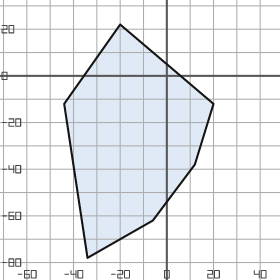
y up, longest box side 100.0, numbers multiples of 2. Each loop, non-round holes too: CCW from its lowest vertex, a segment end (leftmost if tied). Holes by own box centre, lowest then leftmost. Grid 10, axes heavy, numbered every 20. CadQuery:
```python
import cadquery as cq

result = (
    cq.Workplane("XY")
    .moveTo(-34.0, -78.0)
    .lineTo(-6.0, -62.0)
    .lineTo(12.0, -38.0)
    .lineTo(20.0, -12.0)
    .lineTo(-20.0, 22.0)
    .lineTo(-44.0, -12.0)
    .close()
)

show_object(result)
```